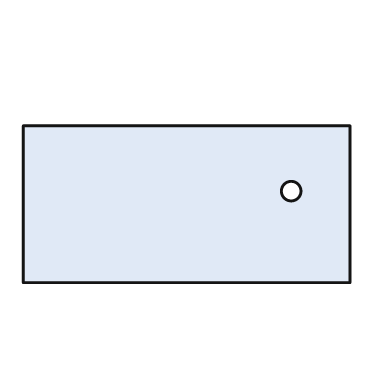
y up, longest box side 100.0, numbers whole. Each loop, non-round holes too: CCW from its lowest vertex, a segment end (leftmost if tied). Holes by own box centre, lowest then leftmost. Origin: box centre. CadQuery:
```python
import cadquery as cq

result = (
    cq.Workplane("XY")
    .moveTo(-50.0, -24.0)
    .lineTo(50.0, -24.0)
    .lineTo(50.0, 24.0)
    .lineTo(-50.0, 24.0)
    .close()
    .moveTo(32.0, 4.0)
    .circle(3.0)
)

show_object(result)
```